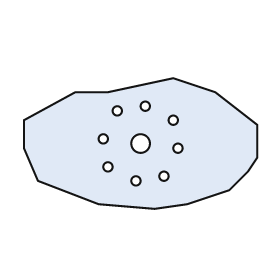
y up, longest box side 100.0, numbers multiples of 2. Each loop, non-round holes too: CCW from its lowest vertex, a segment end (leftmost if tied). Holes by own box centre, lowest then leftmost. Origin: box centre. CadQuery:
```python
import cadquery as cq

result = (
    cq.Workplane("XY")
    .moveTo(6.0, -28.0)
    .lineTo(20.0, -26.0)
    .lineTo(38.0, -20.0)
    .lineTo(46.0, -12.0)
    .lineTo(50.0, -6.0)
    .lineTo(50.0, 8.0)
    .lineTo(32.0, 22.0)
    .lineTo(14.0, 28.0)
    .lineTo(-14.0, 22.0)
    .lineTo(-28.0, 22.0)
    .lineTo(-50.0, 10.0)
    .lineTo(-50.0, -2.0)
    .lineTo(-44.0, -16.0)
    .lineTo(-18.0, -26.0)
    .close()
    .moveTo(-2.0, -16.0)
    .circle(2.0)
    .moveTo(10.0, -14.0)
    .circle(2.0)
    .moveTo(-14.0, -10.0)
    .circle(2.0)
    .moveTo(16.0, -2.0)
    .circle(2.0)
    .moveTo(0.0, 0.0)
    .circle(4.0)
    .moveTo(-16.0, 2.0)
    .circle(2.0)
    .moveTo(14.0, 10.0)
    .circle(2.0)
    .moveTo(-10.0, 14.0)
    .circle(2.0)
    .moveTo(2.0, 16.0)
    .circle(2.0)
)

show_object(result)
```